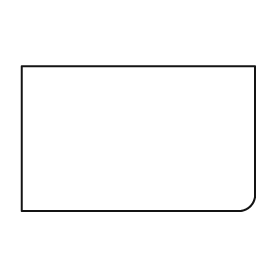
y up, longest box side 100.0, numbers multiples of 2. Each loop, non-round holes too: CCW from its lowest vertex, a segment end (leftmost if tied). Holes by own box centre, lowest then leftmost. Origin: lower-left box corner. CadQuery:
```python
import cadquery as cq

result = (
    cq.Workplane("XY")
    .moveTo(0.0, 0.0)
    .lineTo(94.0, 0.0)
    .threePointArc((98.0, 2.0), (100.0, 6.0))
    .lineTo(100.0, 62.0)
    .lineTo(0.0, 62.0)
    .close()
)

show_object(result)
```